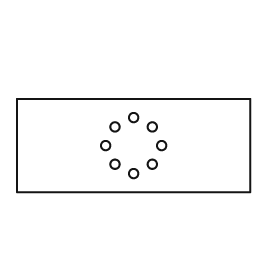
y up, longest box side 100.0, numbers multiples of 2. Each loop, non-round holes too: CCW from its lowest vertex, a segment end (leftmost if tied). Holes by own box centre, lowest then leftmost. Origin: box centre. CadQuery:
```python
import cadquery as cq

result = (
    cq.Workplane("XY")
    .moveTo(-50.0, -20.0)
    .lineTo(50.0, -20.0)
    .lineTo(50.0, 20.0)
    .lineTo(-50.0, 20.0)
    .close()
    .moveTo(0.0, -12.0)
    .circle(2.0)
    .moveTo(-8.0, -8.0)
    .circle(2.0)
    .moveTo(8.0, -8.0)
    .circle(2.0)
    .moveTo(-12.0, 0.0)
    .circle(2.0)
    .moveTo(12.0, 0.0)
    .circle(2.0)
    .moveTo(-8.0, 8.0)
    .circle(2.0)
    .moveTo(8.0, 8.0)
    .circle(2.0)
    .moveTo(0.0, 12.0)
    .circle(2.0)
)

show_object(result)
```